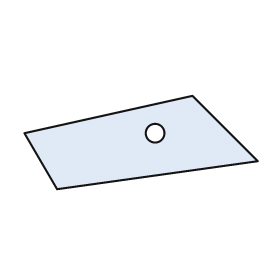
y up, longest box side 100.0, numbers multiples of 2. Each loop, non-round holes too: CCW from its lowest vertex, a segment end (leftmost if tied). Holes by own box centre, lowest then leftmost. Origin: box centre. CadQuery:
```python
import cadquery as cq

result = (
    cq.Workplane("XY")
    .moveTo(-36.0, -20.0)
    .lineTo(50.0, -8.0)
    .lineTo(22.0, 20.0)
    .lineTo(-50.0, 4.0)
    .close()
    .moveTo(6.0, 4.0)
    .circle(4.0)
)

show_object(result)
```